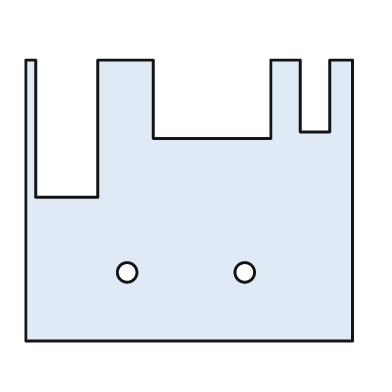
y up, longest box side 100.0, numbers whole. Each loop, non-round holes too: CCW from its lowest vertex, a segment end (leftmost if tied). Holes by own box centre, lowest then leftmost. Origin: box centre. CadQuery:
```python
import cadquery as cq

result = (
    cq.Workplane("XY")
    .moveTo(-50.0, -43.0)
    .lineTo(50.0, -43.0)
    .lineTo(50.0, 43.0)
    .lineTo(43.0, 43.0)
    .lineTo(43.0, 21.0)
    .lineTo(34.0, 21.0)
    .lineTo(34.0, 43.0)
    .lineTo(25.0, 43.0)
    .lineTo(25.0, 19.0)
    .lineTo(-11.0, 19.0)
    .lineTo(-11.0, 43.0)
    .lineTo(-28.0, 43.0)
    .lineTo(-28.0, 1.0)
    .lineTo(-47.0, 1.0)
    .lineTo(-47.0, 43.0)
    .lineTo(-50.0, 43.0)
    .close()
    .moveTo(-19.0, -22.0)
    .circle(3.0)
    .moveTo(17.0, -22.0)
    .circle(3.0)
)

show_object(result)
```